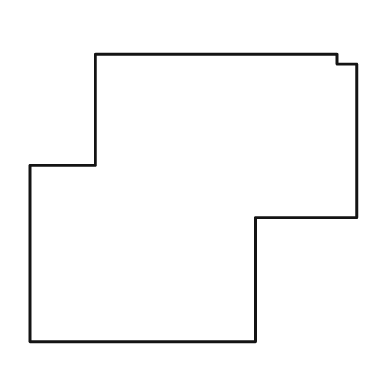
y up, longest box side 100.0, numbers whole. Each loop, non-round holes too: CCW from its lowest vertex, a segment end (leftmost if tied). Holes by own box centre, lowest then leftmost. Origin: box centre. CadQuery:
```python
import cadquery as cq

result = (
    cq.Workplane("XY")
    .moveTo(-50.0, -44.0)
    .lineTo(19.0, -44.0)
    .lineTo(19.0, -6.0)
    .lineTo(50.0, -6.0)
    .lineTo(50.0, 41.0)
    .lineTo(44.0, 41.0)
    .lineTo(44.0, 44.0)
    .lineTo(-30.0, 44.0)
    .lineTo(-30.0, 10.0)
    .lineTo(-50.0, 10.0)
    .close()
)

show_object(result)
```